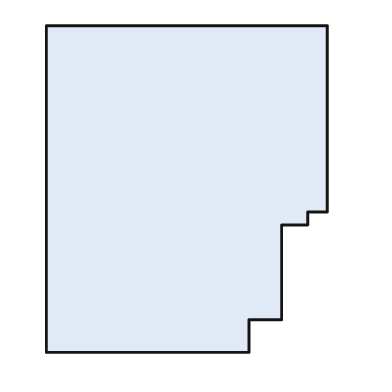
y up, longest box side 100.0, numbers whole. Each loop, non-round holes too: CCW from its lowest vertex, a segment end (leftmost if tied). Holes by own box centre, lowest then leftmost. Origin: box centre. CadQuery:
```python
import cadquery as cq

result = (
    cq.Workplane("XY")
    .moveTo(-43.0, -50.0)
    .lineTo(19.0, -50.0)
    .lineTo(19.0, -40.0)
    .lineTo(29.0, -40.0)
    .lineTo(29.0, -11.0)
    .lineTo(37.0, -11.0)
    .lineTo(37.0, -7.0)
    .lineTo(43.0, -7.0)
    .lineTo(43.0, 50.0)
    .lineTo(-43.0, 50.0)
    .close()
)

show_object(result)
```